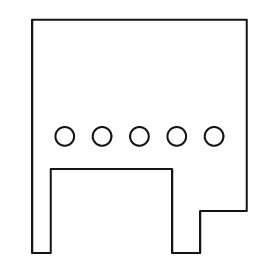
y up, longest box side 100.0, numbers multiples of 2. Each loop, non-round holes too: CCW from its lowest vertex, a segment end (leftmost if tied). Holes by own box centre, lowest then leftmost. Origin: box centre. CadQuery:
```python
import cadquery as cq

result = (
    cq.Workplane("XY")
    .moveTo(-46.0, -50.0)
    .lineTo(-38.0, -50.0)
    .lineTo(-38.0, -14.0)
    .lineTo(14.0, -14.0)
    .lineTo(14.0, -50.0)
    .lineTo(26.0, -50.0)
    .lineTo(26.0, -32.0)
    .lineTo(46.0, -32.0)
    .lineTo(46.0, 50.0)
    .lineTo(-46.0, 50.0)
    .close()
    .moveTo(-32.0, 0.0)
    .circle(4.0)
    .moveTo(-16.0, 0.0)
    .circle(4.0)
    .moveTo(0.0, 0.0)
    .circle(4.0)
    .moveTo(16.0, 0.0)
    .circle(4.0)
    .moveTo(32.0, 0.0)
    .circle(4.0)
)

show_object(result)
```